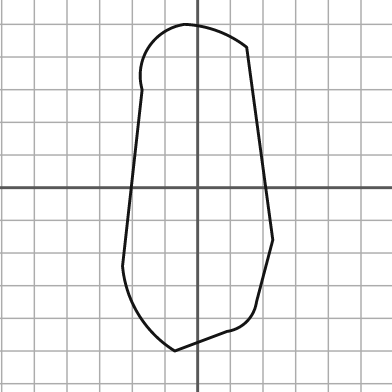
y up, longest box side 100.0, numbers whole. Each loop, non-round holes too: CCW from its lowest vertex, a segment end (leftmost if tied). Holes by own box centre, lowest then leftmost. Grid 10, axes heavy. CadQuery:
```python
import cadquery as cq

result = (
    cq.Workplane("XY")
    .moveTo(-7.0, -50.0)
    .lineTo(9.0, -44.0)
    .threePointArc((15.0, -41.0), (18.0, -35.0))
    .lineTo(23.0, -16.0)
    .lineTo(15.0, 43.0)
    .threePointArc((6.0, 48.0), (-4.0, 50.0))
    .threePointArc((-15.0, 43.0), (-17.0, 30.0))
    .lineTo(-23.0, -24.0)
    .threePointArc((-18.0, -39.0), (-7.0, -50.0))
    .close()
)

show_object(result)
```